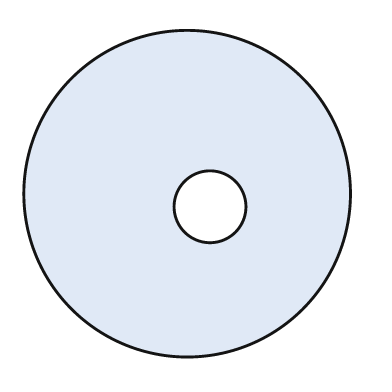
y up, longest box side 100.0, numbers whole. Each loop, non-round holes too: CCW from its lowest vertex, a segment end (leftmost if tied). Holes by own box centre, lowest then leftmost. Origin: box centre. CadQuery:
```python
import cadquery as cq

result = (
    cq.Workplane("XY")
    .moveTo(0.0, 0.0)
    .circle(50.0)
    .moveTo(7.0, -4.0)
    .circle(11.0)
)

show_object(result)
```